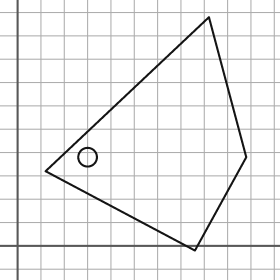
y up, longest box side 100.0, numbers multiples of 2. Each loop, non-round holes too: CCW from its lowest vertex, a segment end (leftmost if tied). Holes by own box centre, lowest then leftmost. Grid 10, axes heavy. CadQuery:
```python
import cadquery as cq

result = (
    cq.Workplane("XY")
    .moveTo(76.0, -2.0)
    .lineTo(98.0, 38.0)
    .lineTo(82.0, 98.0)
    .lineTo(12.0, 32.0)
    .close()
    .moveTo(30.0, 38.0)
    .circle(4.0)
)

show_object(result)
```